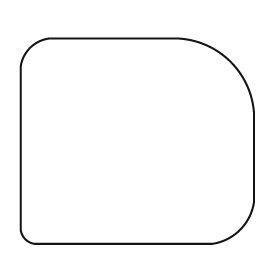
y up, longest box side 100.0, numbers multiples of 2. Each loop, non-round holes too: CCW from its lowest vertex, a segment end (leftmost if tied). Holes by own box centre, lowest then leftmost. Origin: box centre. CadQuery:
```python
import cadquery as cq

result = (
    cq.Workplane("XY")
    .moveTo(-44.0, -44.0)
    .lineTo(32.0, -44.0)
    .threePointArc((44.0, -38.0), (50.0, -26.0))
    .lineTo(50.0, 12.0)
    .threePointArc((40.0, 34.0), (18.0, 44.0))
    .lineTo(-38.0, 44.0)
    .threePointArc((-46.0, 40.0), (-50.0, 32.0))
    .lineTo(-50.0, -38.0)
    .threePointArc((-48.0, -42.0), (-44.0, -44.0))
    .close()
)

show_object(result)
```